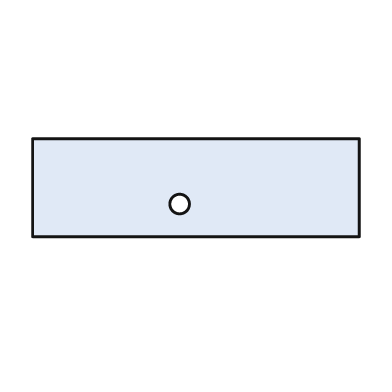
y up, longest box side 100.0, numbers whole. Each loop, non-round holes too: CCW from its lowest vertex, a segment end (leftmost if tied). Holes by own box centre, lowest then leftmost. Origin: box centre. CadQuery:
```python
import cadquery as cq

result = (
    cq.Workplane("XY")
    .moveTo(-50.0, -15.0)
    .lineTo(50.0, -15.0)
    .lineTo(50.0, 15.0)
    .lineTo(-50.0, 15.0)
    .close()
    .moveTo(-5.0, -5.0)
    .circle(3.0)
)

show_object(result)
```